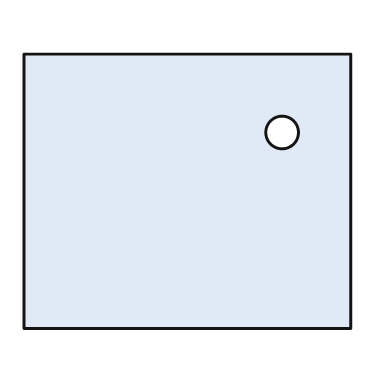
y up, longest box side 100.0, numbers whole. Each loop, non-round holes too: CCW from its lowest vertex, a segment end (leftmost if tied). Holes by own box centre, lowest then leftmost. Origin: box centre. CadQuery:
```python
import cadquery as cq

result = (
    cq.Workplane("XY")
    .moveTo(-50.0, -42.0)
    .lineTo(50.0, -42.0)
    .lineTo(50.0, 42.0)
    .lineTo(-50.0, 42.0)
    .close()
    .moveTo(29.0, 18.0)
    .circle(5.0)
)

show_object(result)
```